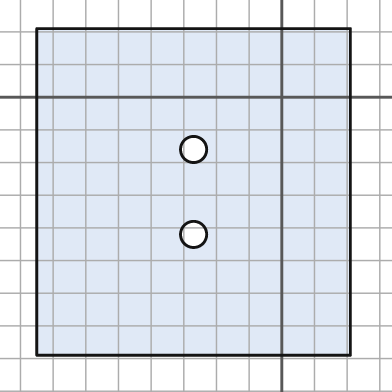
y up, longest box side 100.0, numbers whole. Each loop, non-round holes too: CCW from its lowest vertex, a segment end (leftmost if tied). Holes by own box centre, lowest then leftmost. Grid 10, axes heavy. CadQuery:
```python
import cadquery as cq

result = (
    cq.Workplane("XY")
    .moveTo(-75.0, -79.0)
    .lineTo(21.0, -79.0)
    .lineTo(21.0, 21.0)
    .lineTo(-75.0, 21.0)
    .close()
    .moveTo(-27.0, -42.0)
    .circle(4.0)
    .moveTo(-27.0, -16.0)
    .circle(4.0)
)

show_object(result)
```